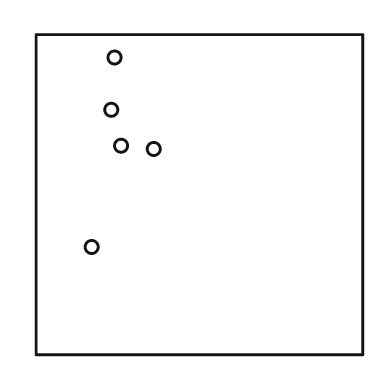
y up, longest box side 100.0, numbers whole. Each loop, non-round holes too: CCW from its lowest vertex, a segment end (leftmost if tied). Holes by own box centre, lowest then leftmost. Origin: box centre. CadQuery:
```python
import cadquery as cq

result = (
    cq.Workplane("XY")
    .moveTo(-50.0, -49.0)
    .lineTo(50.0, -49.0)
    .lineTo(50.0, 49.0)
    .lineTo(-50.0, 49.0)
    .close()
    .moveTo(-33.0, -16.0)
    .circle(2.0)
    .moveTo(-14.0, 14.0)
    .circle(2.0)
    .moveTo(-24.0, 15.0)
    .circle(2.0)
    .moveTo(-27.0, 26.0)
    .circle(2.0)
    .moveTo(-26.0, 42.0)
    .circle(2.0)
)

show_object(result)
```